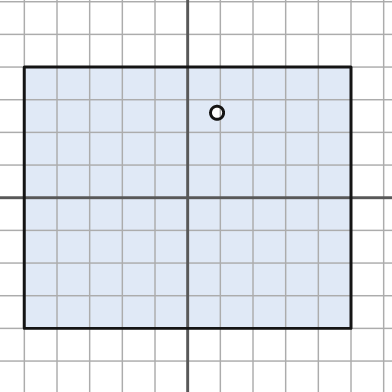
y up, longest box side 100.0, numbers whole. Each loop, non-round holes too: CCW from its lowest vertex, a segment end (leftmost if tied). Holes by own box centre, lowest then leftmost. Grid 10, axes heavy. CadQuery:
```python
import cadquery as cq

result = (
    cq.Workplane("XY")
    .moveTo(-50.0, -40.0)
    .lineTo(50.0, -40.0)
    .lineTo(50.0, 40.0)
    .lineTo(-50.0, 40.0)
    .close()
    .moveTo(9.0, 26.0)
    .circle(2.0)
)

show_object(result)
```